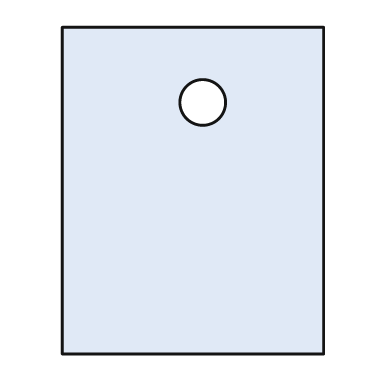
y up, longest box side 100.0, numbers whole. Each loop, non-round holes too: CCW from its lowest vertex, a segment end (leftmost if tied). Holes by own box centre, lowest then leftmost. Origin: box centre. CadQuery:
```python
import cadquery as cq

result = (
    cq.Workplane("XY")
    .moveTo(-40.0, -50.0)
    .lineTo(40.0, -50.0)
    .lineTo(40.0, 50.0)
    .lineTo(-40.0, 50.0)
    .close()
    .moveTo(3.0, 27.0)
    .circle(7.0)
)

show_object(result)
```